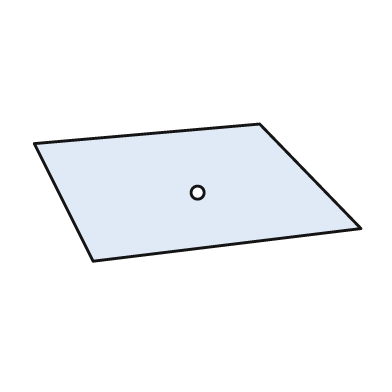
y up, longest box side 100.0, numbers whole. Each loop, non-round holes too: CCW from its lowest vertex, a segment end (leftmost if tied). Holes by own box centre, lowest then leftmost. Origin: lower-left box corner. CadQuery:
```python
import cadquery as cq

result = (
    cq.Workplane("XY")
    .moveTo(18.0, 0.0)
    .lineTo(100.0, 10.0)
    .lineTo(69.0, 42.0)
    .lineTo(0.0, 36.0)
    .close()
    .moveTo(50.0, 21.0)
    .circle(2.0)
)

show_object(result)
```